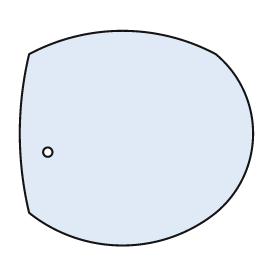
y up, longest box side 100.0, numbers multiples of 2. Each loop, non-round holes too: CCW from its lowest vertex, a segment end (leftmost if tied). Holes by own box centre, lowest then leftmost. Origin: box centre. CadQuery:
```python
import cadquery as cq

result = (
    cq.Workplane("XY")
    .moveTo(-46.0, -32.0)
    .threePointArc((-6.0, -46.0), (34.0, -32.0))
    .threePointArc((50.0, 2.0), (34.0, 36.0))
    .threePointArc((-6.0, 46.0), (-46.0, 36.0))
    .threePointArc((-50.0, 2.0), (-46.0, -32.0))
    .close()
    .moveTo(-38.0, -6.0)
    .circle(2.0)
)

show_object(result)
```